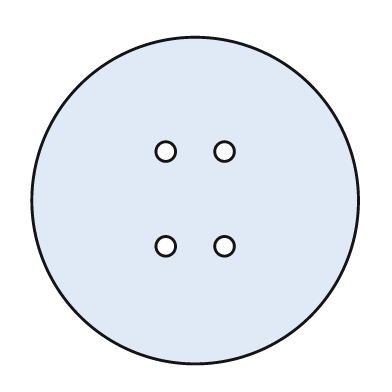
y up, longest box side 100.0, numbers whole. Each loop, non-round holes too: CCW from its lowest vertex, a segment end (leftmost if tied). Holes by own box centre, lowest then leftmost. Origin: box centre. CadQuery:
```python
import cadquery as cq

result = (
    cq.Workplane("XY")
    .moveTo(0.0, 0.0)
    .circle(50.0)
    .moveTo(-9.0, -14.0)
    .circle(3.0)
    .moveTo(9.0, -14.0)
    .circle(3.0)
    .moveTo(-9.0, 15.0)
    .circle(3.0)
    .moveTo(9.0, 15.0)
    .circle(3.0)
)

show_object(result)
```